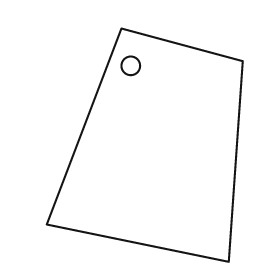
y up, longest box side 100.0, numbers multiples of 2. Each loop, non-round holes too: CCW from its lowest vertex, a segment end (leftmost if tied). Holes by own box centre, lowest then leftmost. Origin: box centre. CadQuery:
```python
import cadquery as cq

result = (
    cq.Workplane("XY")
    .moveTo(36.0, -50.0)
    .lineTo(42.0, 36.0)
    .lineTo(-10.0, 50.0)
    .lineTo(-42.0, -34.0)
    .close()
    .moveTo(-6.0, 34.0)
    .circle(4.0)
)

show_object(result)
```